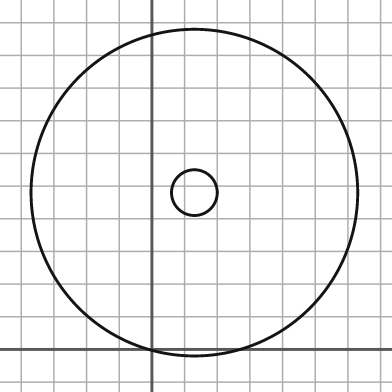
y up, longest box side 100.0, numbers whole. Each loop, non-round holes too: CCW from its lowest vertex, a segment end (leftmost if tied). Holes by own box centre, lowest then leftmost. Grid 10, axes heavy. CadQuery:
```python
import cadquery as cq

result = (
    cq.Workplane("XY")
    .moveTo(13.0, 48.0)
    .circle(50.0)
    .moveTo(13.0, 48.0)
    .circle(7.0)
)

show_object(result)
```